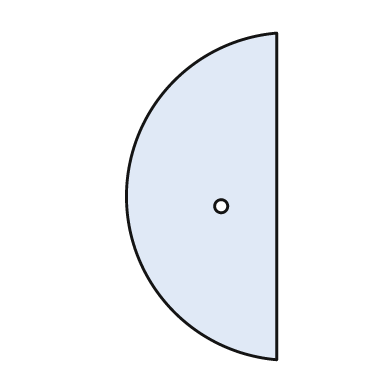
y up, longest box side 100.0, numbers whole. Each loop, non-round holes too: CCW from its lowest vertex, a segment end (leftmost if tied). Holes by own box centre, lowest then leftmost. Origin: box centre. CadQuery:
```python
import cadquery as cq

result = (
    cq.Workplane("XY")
    .moveTo(23.0, -50.0)
    .lineTo(23.0, 50.0)
    .threePointArc((-23.0, 0.0), (23.0, -50.0))
    .close()
    .moveTo(6.0, -3.0)
    .circle(2.0)
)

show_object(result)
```